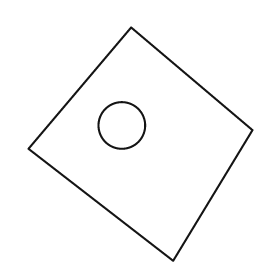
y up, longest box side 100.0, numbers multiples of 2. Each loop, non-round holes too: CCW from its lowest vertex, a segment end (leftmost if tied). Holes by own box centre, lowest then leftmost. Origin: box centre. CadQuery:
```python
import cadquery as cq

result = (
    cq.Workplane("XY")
    .moveTo(14.0, -50.0)
    .lineTo(48.0, 6.0)
    .lineTo(-4.0, 50.0)
    .lineTo(-48.0, -2.0)
    .close()
    .moveTo(-8.0, 8.0)
    .circle(10.0)
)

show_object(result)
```